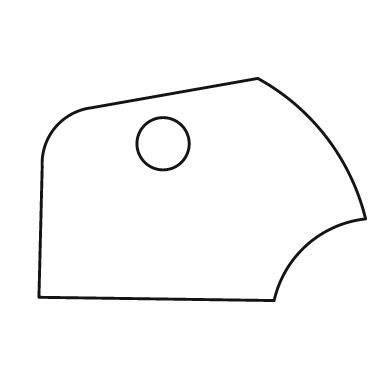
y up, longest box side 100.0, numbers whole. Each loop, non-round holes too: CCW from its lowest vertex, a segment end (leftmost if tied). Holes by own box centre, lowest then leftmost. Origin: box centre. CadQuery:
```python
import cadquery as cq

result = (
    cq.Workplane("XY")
    .moveTo(22.0, -34.0)
    .threePointArc((32.0, -17.0), (50.0, -9.0))
    .threePointArc((38.0, 16.0), (17.0, 34.0))
    .lineTo(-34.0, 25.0)
    .threePointArc((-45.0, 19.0), (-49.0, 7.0))
    .lineTo(-50.0, -33.0)
    .close()
    .moveTo(-12.0, 14.0)
    .circle(8.0)
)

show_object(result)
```